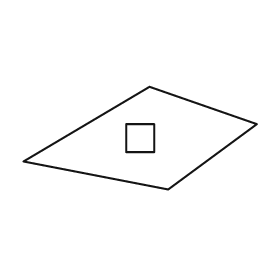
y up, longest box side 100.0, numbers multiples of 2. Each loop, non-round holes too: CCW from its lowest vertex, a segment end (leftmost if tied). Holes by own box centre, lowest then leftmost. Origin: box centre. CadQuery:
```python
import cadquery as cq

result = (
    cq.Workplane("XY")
    .moveTo(12.0, -22.0)
    .lineTo(50.0, 6.0)
    .lineTo(4.0, 22.0)
    .lineTo(-50.0, -10.0)
    .close()
    .moveTo(-6.0, -6.0)
    .lineTo(6.0, -6.0)
    .lineTo(6.0, 6.0)
    .lineTo(-6.0, 6.0)
    .close()
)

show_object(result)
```